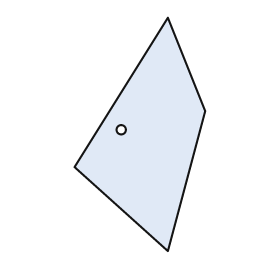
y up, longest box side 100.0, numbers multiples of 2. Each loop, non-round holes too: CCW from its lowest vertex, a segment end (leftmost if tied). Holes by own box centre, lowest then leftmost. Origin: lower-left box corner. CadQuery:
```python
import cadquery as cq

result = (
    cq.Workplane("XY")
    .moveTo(40.0, 0.0)
    .lineTo(56.0, 60.0)
    .lineTo(40.0, 100.0)
    .lineTo(0.0, 36.0)
    .close()
    .moveTo(20.0, 52.0)
    .circle(2.0)
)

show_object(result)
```